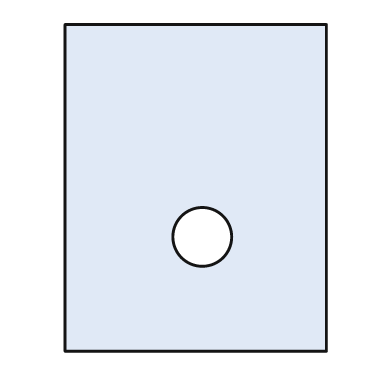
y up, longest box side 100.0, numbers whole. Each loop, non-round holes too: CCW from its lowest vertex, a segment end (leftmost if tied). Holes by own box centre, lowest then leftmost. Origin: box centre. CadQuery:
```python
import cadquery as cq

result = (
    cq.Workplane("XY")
    .moveTo(-40.0, -50.0)
    .lineTo(40.0, -50.0)
    .lineTo(40.0, 50.0)
    .lineTo(-40.0, 50.0)
    .close()
    .moveTo(2.0, -15.0)
    .circle(9.0)
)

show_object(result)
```